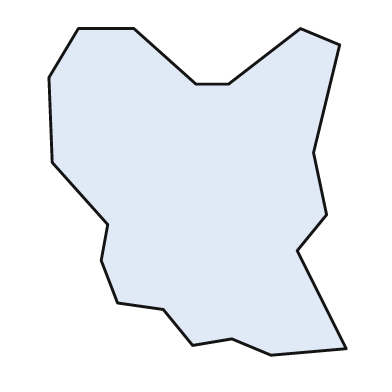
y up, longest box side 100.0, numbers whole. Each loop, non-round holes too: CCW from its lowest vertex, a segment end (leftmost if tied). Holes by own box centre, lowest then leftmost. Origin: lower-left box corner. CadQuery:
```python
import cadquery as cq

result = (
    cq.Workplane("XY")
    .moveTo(68.0, 0.0)
    .lineTo(91.0, 2.0)
    .lineTo(76.0, 32.0)
    .lineTo(85.0, 43.0)
    .lineTo(81.0, 62.0)
    .lineTo(89.0, 95.0)
    .lineTo(77.0, 100.0)
    .lineTo(55.0, 83.0)
    .lineTo(45.0, 83.0)
    .lineTo(26.0, 100.0)
    .lineTo(9.0, 100.0)
    .lineTo(0.0, 85.0)
    .lineTo(1.0, 59.0)
    .lineTo(18.0, 40.0)
    .lineTo(16.0, 29.0)
    .lineTo(21.0, 16.0)
    .lineTo(35.0, 14.0)
    .lineTo(44.0, 3.0)
    .lineTo(56.0, 5.0)
    .close()
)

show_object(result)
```